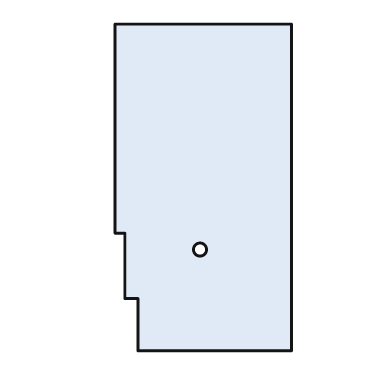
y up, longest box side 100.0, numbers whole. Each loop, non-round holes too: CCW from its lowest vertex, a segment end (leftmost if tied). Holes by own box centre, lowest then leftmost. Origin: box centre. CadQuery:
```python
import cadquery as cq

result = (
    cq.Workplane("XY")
    .moveTo(-20.0, -50.0)
    .lineTo(27.0, -50.0)
    .lineTo(27.0, 50.0)
    .lineTo(-27.0, 50.0)
    .lineTo(-27.0, -14.0)
    .lineTo(-24.0, -14.0)
    .lineTo(-24.0, -34.0)
    .lineTo(-20.0, -34.0)
    .close()
    .moveTo(-1.0, -19.0)
    .circle(2.0)
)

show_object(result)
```